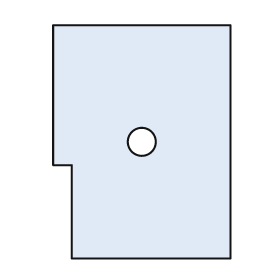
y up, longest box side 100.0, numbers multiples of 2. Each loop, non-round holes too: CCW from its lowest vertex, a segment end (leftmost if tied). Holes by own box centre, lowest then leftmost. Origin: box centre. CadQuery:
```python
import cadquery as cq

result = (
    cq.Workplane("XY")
    .moveTo(-30.0, -50.0)
    .lineTo(38.0, -50.0)
    .lineTo(38.0, 50.0)
    .lineTo(-38.0, 50.0)
    .lineTo(-38.0, -10.0)
    .lineTo(-30.0, -10.0)
    .close()
    .moveTo(0.0, 0.0)
    .circle(6.0)
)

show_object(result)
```